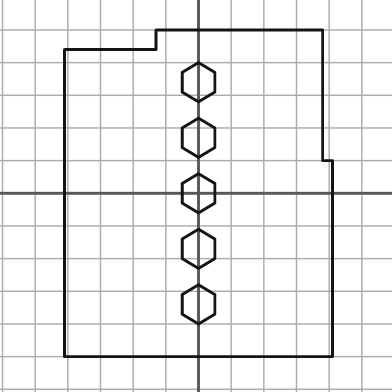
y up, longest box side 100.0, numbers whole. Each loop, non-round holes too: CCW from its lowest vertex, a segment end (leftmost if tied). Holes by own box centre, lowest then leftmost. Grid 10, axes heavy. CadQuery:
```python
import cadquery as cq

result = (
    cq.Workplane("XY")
    .moveTo(-41.0, -50.0)
    .lineTo(41.0, -50.0)
    .lineTo(41.0, 10.0)
    .lineTo(38.0, 10.0)
    .lineTo(38.0, 50.0)
    .lineTo(-13.0, 50.0)
    .lineTo(-13.0, 44.0)
    .lineTo(-41.0, 44.0)
    .close()
    .moveTo(0.0, -40.0)
    .lineTo(5.0, -37.0)
    .lineTo(5.0, -31.0)
    .lineTo(0.0, -28.0)
    .lineTo(-5.0, -31.0)
    .lineTo(-5.0, -37.0)
    .close()
    .moveTo(0.0, -23.0)
    .lineTo(5.0, -20.0)
    .lineTo(5.0, -14.0)
    .lineTo(0.0, -11.0)
    .lineTo(-5.0, -14.0)
    .lineTo(-5.0, -20.0)
    .close()
    .moveTo(0.0, -6.0)
    .lineTo(5.0, -3.0)
    .lineTo(5.0, 3.0)
    .lineTo(0.0, 6.0)
    .lineTo(-5.0, 3.0)
    .lineTo(-5.0, -3.0)
    .close()
    .moveTo(0.0, 11.0)
    .lineTo(5.0, 14.0)
    .lineTo(5.0, 20.0)
    .lineTo(0.0, 23.0)
    .lineTo(-5.0, 20.0)
    .lineTo(-5.0, 14.0)
    .close()
    .moveTo(0.0, 28.0)
    .lineTo(5.0, 31.0)
    .lineTo(5.0, 37.0)
    .lineTo(0.0, 40.0)
    .lineTo(-5.0, 37.0)
    .lineTo(-5.0, 31.0)
    .close()
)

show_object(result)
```